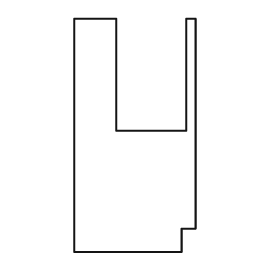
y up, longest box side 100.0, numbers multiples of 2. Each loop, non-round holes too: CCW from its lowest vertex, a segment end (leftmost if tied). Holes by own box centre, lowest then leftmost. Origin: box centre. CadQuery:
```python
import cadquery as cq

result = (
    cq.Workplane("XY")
    .moveTo(-26.0, -50.0)
    .lineTo(20.0, -50.0)
    .lineTo(20.0, -40.0)
    .lineTo(26.0, -40.0)
    .lineTo(26.0, 50.0)
    .lineTo(22.0, 50.0)
    .lineTo(22.0, 2.0)
    .lineTo(-8.0, 2.0)
    .lineTo(-8.0, 50.0)
    .lineTo(-26.0, 50.0)
    .close()
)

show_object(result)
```